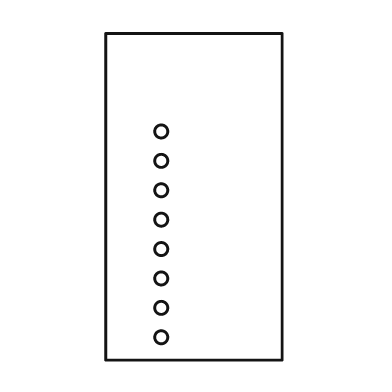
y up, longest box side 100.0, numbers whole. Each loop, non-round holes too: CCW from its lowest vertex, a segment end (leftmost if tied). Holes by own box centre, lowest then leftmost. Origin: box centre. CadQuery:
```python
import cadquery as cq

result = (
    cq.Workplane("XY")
    .moveTo(-27.0, -50.0)
    .lineTo(27.0, -50.0)
    .lineTo(27.0, 50.0)
    .lineTo(-27.0, 50.0)
    .close()
    .moveTo(-10.0, -43.0)
    .circle(2.0)
    .moveTo(-10.0, -34.0)
    .circle(2.0)
    .moveTo(-10.0, -25.0)
    .circle(2.0)
    .moveTo(-10.0, -16.0)
    .circle(2.0)
    .moveTo(-10.0, -7.0)
    .circle(2.0)
    .moveTo(-10.0, 2.0)
    .circle(2.0)
    .moveTo(-10.0, 11.0)
    .circle(2.0)
    .moveTo(-10.0, 20.0)
    .circle(2.0)
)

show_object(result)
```